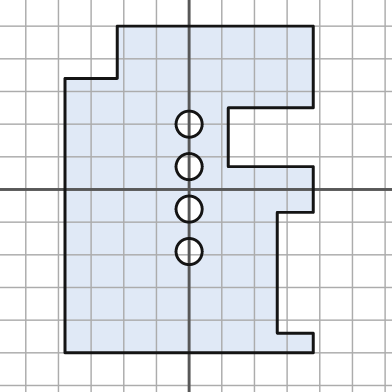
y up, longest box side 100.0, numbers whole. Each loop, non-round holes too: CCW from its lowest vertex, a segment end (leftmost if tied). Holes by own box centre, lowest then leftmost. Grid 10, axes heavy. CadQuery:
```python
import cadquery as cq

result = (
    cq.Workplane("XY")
    .moveTo(-38.0, -50.0)
    .lineTo(38.0, -50.0)
    .lineTo(38.0, -44.0)
    .lineTo(27.0, -44.0)
    .lineTo(27.0, -7.0)
    .lineTo(38.0, -7.0)
    .lineTo(38.0, 7.0)
    .lineTo(12.0, 7.0)
    .lineTo(12.0, 25.0)
    .lineTo(38.0, 25.0)
    .lineTo(38.0, 50.0)
    .lineTo(-22.0, 50.0)
    .lineTo(-22.0, 34.0)
    .lineTo(-38.0, 34.0)
    .close()
    .moveTo(0.0, -19.0)
    .circle(4.0)
    .moveTo(0.0, -6.0)
    .circle(4.0)
    .moveTo(0.0, 7.0)
    .circle(4.0)
    .moveTo(0.0, 20.0)
    .circle(4.0)
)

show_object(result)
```